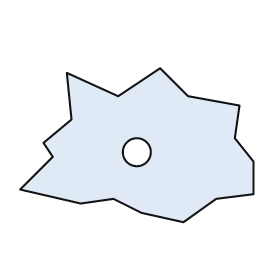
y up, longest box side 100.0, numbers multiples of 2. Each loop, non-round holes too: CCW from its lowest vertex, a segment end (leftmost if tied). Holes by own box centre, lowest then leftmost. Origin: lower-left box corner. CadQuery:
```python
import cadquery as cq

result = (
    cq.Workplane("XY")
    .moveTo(70.0, 0.0)
    .lineTo(84.0, 10.0)
    .lineTo(100.0, 12.0)
    .lineTo(100.0, 26.0)
    .lineTo(92.0, 36.0)
    .lineTo(94.0, 50.0)
    .lineTo(72.0, 54.0)
    .lineTo(60.0, 66.0)
    .lineTo(42.0, 54.0)
    .lineTo(20.0, 64.0)
    .lineTo(22.0, 44.0)
    .lineTo(10.0, 34.0)
    .lineTo(14.0, 28.0)
    .lineTo(0.0, 14.0)
    .lineTo(26.0, 8.0)
    .lineTo(40.0, 10.0)
    .lineTo(52.0, 4.0)
    .close()
    .moveTo(50.0, 30.0)
    .circle(6.0)
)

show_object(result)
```